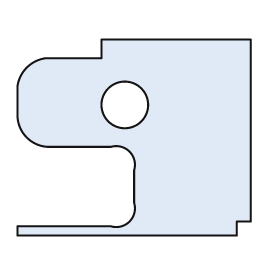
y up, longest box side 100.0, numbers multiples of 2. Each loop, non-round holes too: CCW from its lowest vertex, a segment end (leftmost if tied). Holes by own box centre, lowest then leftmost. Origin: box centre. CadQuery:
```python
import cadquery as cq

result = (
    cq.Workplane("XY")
    .moveTo(-50.0, -42.0)
    .lineTo(44.0, -42.0)
    .lineTo(44.0, -36.0)
    .lineTo(50.0, -36.0)
    .lineTo(50.0, 42.0)
    .lineTo(-14.0, 42.0)
    .lineTo(-14.0, 34.0)
    .lineTo(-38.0, 34.0)
    .threePointArc((-46.0, 30.0), (-50.0, 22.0))
    .lineTo(-50.0, 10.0)
    .threePointArc((-46.0, 0.0), (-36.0, -4.0))
    .lineTo(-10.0, -4.0)
    .threePointArc((-2.0, -6.0), (0.0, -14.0))
    .lineTo(0.0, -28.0)
    .threePointArc((-2.0, -36.0), (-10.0, -38.0))
    .lineTo(-50.0, -38.0)
    .close()
    .moveTo(-4.0, 14.0)
    .circle(10.0)
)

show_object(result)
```